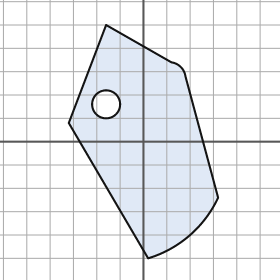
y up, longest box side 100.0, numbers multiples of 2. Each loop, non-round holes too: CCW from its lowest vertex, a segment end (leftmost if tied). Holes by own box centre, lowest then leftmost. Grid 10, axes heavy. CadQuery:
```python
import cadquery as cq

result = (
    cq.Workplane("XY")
    .moveTo(2.0, -50.0)
    .threePointArc((20.0, -40.0), (32.0, -24.0))
    .lineTo(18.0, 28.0)
    .threePointArc((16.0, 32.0), (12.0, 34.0))
    .lineTo(-16.0, 50.0)
    .lineTo(-32.0, 8.0)
    .close()
    .moveTo(-16.0, 16.0)
    .circle(6.0)
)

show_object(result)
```